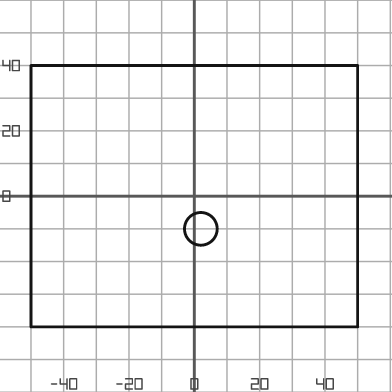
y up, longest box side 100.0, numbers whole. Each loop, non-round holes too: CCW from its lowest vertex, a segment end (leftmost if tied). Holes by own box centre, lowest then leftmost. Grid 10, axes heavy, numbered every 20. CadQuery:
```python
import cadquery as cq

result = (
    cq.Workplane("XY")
    .moveTo(-50.0, -40.0)
    .lineTo(50.0, -40.0)
    .lineTo(50.0, 40.0)
    .lineTo(-50.0, 40.0)
    .close()
    .moveTo(2.0, -10.0)
    .circle(5.0)
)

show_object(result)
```